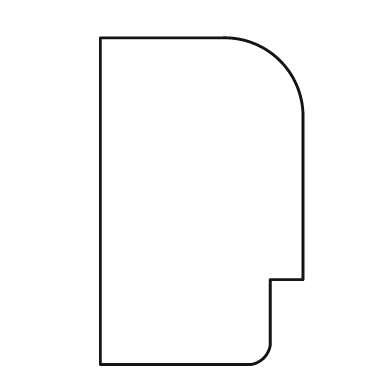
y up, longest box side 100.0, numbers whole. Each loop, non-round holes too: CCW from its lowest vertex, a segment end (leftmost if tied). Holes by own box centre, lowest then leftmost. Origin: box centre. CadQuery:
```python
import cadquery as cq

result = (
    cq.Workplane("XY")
    .moveTo(-31.0, -50.0)
    .lineTo(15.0, -50.0)
    .threePointArc((19.0, -48.0), (21.0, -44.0))
    .lineTo(21.0, -24.0)
    .lineTo(31.0, -24.0)
    .lineTo(31.0, 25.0)
    .threePointArc((24.0, 43.0), (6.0, 50.0))
    .lineTo(-31.0, 50.0)
    .close()
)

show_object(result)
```